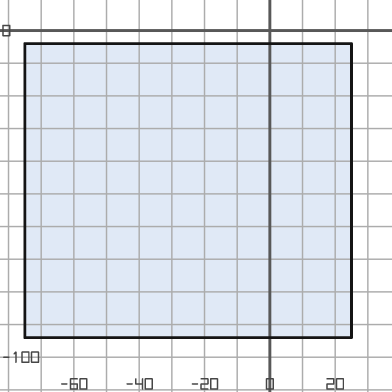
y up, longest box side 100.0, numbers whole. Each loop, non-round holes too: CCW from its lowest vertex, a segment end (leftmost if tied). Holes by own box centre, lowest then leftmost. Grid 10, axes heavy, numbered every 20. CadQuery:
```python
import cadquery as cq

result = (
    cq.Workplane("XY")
    .moveTo(-75.0, -94.0)
    .lineTo(25.0, -94.0)
    .lineTo(25.0, -4.0)
    .lineTo(-75.0, -4.0)
    .close()
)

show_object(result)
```